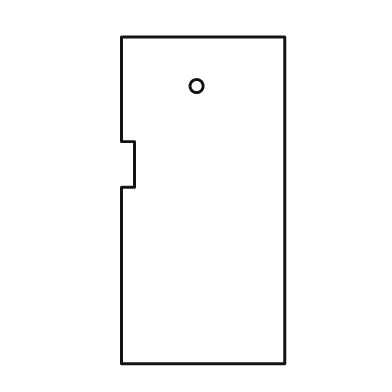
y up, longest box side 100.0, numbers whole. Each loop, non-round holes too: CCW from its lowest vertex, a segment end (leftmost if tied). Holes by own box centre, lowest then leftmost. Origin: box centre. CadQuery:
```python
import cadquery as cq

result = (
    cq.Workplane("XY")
    .moveTo(-25.0, -50.0)
    .lineTo(25.0, -50.0)
    .lineTo(25.0, 50.0)
    .lineTo(-25.0, 50.0)
    .lineTo(-25.0, 18.0)
    .lineTo(-21.0, 18.0)
    .lineTo(-21.0, 4.0)
    .lineTo(-25.0, 4.0)
    .close()
    .moveTo(-2.0, 35.0)
    .circle(2.0)
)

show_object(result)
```